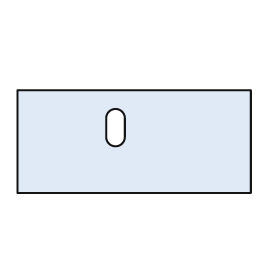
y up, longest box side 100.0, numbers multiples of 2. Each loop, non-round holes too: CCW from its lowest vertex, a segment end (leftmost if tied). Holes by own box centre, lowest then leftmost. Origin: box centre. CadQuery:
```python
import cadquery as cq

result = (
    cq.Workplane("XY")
    .moveTo(-50.0, -22.0)
    .lineTo(50.0, -22.0)
    .lineTo(50.0, 22.0)
    .lineTo(-50.0, 22.0)
    .close()
    .moveTo(-12.0, 2.0)
    .threePointArc((-8.0, -2.0), (-4.0, 2.0))
    .lineTo(-4.0, 10.0)
    .threePointArc((-8.0, 14.0), (-12.0, 10.0))
    .close()
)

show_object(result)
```